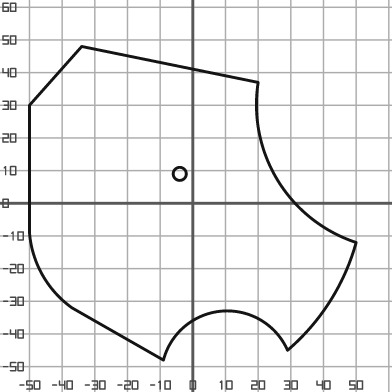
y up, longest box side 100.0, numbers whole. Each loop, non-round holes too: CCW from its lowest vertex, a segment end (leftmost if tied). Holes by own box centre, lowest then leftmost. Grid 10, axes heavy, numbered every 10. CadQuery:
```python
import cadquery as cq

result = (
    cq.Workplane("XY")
    .moveTo(-9.0, -48.0)
    .threePointArc((9.0, -33.0), (29.0, -45.0))
    .threePointArc((42.0, -30.0), (50.0, -12.0))
    .threePointArc((26.0, 7.0), (20.0, 37.0))
    .lineTo(-34.0, 48.0)
    .lineTo(-50.0, 30.0)
    .lineTo(-50.0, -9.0)
    .threePointArc((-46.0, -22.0), (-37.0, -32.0))
    .close()
    .moveTo(-4.0, 9.0)
    .circle(2.0)
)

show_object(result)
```